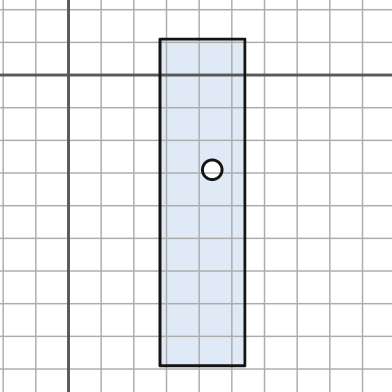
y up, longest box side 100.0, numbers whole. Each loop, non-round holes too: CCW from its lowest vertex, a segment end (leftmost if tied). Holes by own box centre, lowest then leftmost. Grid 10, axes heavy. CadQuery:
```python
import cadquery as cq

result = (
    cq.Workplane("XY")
    .moveTo(28.0, -89.0)
    .lineTo(54.0, -89.0)
    .lineTo(54.0, 11.0)
    .lineTo(28.0, 11.0)
    .close()
    .moveTo(44.0, -29.0)
    .circle(3.0)
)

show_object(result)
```